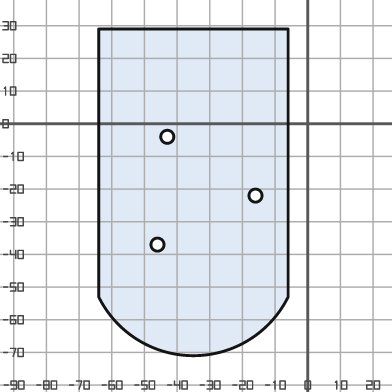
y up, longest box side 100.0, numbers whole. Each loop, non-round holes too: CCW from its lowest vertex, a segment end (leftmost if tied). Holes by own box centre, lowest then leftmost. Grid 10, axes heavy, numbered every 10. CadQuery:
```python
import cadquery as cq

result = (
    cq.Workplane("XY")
    .moveTo(-64.0, -53.0)
    .threePointArc((-35.0, -71.0), (-6.0, -53.0))
    .lineTo(-6.0, 29.0)
    .lineTo(-64.0, 29.0)
    .close()
    .moveTo(-46.0, -37.0)
    .circle(2.0)
    .moveTo(-16.0, -22.0)
    .circle(2.0)
    .moveTo(-43.0, -4.0)
    .circle(2.0)
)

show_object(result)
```